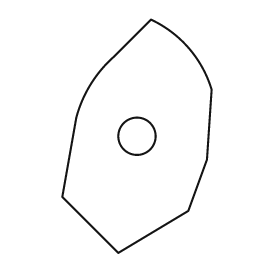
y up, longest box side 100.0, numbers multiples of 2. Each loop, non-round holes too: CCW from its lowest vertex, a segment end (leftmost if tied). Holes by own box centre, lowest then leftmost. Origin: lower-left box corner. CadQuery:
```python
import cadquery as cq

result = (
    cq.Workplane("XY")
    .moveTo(24.0, 0.0)
    .lineTo(54.0, 18.0)
    .lineTo(62.0, 40.0)
    .lineTo(64.0, 70.0)
    .threePointArc((54.0, 88.0), (38.0, 100.0))
    .lineTo(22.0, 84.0)
    .threePointArc((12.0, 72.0), (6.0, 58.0))
    .lineTo(0.0, 24.0)
    .close()
    .moveTo(32.0, 50.0)
    .circle(8.0)
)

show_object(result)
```